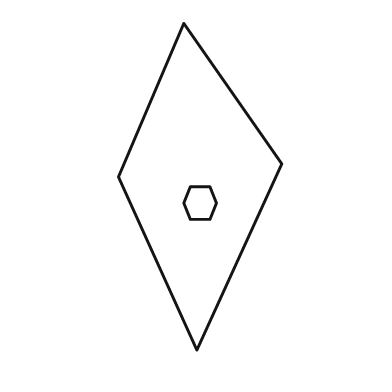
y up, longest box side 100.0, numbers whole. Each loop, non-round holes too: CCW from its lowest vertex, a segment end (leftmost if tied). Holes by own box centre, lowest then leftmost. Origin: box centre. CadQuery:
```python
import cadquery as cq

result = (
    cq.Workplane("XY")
    .moveTo(-1.0, -50.0)
    .lineTo(25.0, 7.0)
    .lineTo(-5.0, 50.0)
    .lineTo(-25.0, 3.0)
    .close()
    .moveTo(-3.0, -10.0)
    .lineTo(3.0, -10.0)
    .lineTo(5.0, -5.0)
    .lineTo(3.0, 0.0)
    .lineTo(-3.0, 0.0)
    .lineTo(-5.0, -5.0)
    .close()
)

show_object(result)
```